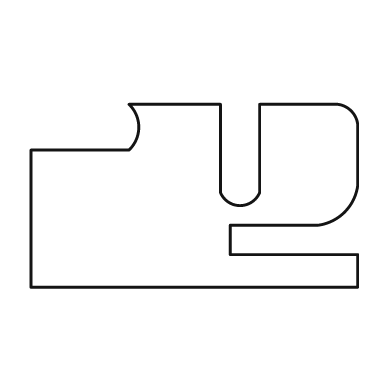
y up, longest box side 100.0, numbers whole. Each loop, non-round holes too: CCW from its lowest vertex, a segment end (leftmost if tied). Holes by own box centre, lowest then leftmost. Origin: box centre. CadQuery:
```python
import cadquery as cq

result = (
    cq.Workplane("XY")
    .moveTo(-50.0, -28.0)
    .lineTo(50.0, -28.0)
    .lineTo(50.0, -18.0)
    .lineTo(11.0, -18.0)
    .lineTo(11.0, -9.0)
    .lineTo(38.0, -9.0)
    .threePointArc((46.0, -5.0), (50.0, 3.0))
    .lineTo(50.0, 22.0)
    .threePointArc((48.0, 26.0), (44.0, 28.0))
    .lineTo(20.0, 28.0)
    .lineTo(20.0, 1.0)
    .threePointArc((14.0, -3.0), (8.0, 1.0))
    .lineTo(8.0, 28.0)
    .lineTo(-20.0, 28.0)
    .threePointArc((-17.0, 21.0), (-20.0, 14.0))
    .lineTo(-50.0, 14.0)
    .close()
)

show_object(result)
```